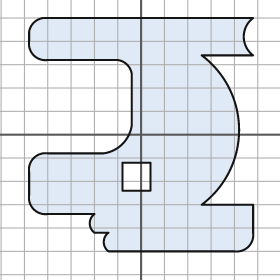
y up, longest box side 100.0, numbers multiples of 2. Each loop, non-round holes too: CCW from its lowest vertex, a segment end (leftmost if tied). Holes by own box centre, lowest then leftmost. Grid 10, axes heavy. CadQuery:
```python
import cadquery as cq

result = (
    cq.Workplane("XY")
    .moveTo(-14.0, -50.0)
    .lineTo(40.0, -50.0)
    .threePointArc((46.0, -48.0), (48.0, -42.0))
    .lineTo(48.0, -30.0)
    .lineTo(26.0, -30.0)
    .threePointArc((42.0, 2.0), (26.0, 34.0))
    .lineTo(48.0, 34.0)
    .threePointArc((44.0, 42.0), (48.0, 50.0))
    .lineTo(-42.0, 50.0)
    .threePointArc((-46.0, 48.0), (-48.0, 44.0))
    .lineTo(-48.0, 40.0)
    .threePointArc((-46.0, 34.0), (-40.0, 32.0))
    .lineTo(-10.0, 32.0)
    .threePointArc((-6.0, 30.0), (-4.0, 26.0))
    .lineTo(-4.0, 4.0)
    .threePointArc((-8.0, -4.0), (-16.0, -8.0))
    .lineTo(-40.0, -8.0)
    .threePointArc((-46.0, -10.0), (-48.0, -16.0))
    .lineTo(-48.0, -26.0)
    .threePointArc((-46.0, -32.0), (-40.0, -34.0))
    .lineTo(-20.0, -34.0)
    .threePointArc((-22.0, -38.0), (-20.0, -42.0))
    .lineTo(-14.0, -42.0)
    .threePointArc((-16.0, -46.0), (-14.0, -50.0))
    .close()
    .moveTo(-8.0, -24.0)
    .lineTo(4.0, -24.0)
    .lineTo(4.0, -12.0)
    .lineTo(-8.0, -12.0)
    .close()
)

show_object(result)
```